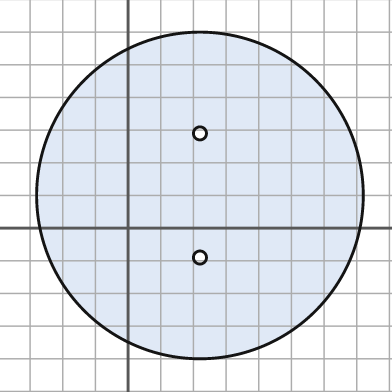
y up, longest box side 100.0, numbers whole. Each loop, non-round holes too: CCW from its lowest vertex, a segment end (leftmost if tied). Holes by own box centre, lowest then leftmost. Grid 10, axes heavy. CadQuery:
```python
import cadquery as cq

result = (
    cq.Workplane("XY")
    .moveTo(22.0, 10.0)
    .circle(50.0)
    .moveTo(22.0, -9.0)
    .circle(2.0)
    .moveTo(22.0, 29.0)
    .circle(2.0)
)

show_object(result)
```